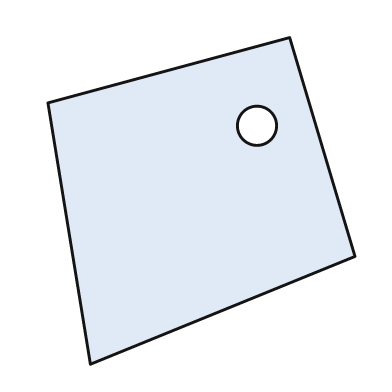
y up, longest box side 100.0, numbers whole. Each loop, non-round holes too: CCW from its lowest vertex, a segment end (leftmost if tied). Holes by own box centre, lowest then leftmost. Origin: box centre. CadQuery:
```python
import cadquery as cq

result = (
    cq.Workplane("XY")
    .moveTo(-34.0, -50.0)
    .lineTo(47.0, -17.0)
    .lineTo(27.0, 50.0)
    .lineTo(-47.0, 30.0)
    .close()
    .moveTo(17.0, 23.0)
    .circle(6.0)
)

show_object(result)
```